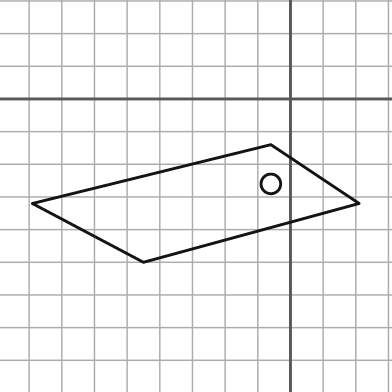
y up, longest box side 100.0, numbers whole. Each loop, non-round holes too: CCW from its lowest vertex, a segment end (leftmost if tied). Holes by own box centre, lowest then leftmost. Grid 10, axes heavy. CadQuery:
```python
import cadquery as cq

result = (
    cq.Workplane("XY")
    .moveTo(-45.0, -50.0)
    .lineTo(21.0, -32.0)
    .lineTo(-6.0, -14.0)
    .lineTo(-79.0, -32.0)
    .close()
    .moveTo(-6.0, -26.0)
    .circle(3.0)
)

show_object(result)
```